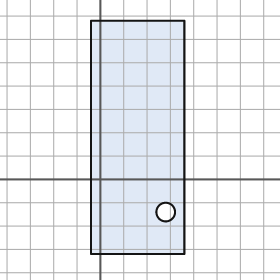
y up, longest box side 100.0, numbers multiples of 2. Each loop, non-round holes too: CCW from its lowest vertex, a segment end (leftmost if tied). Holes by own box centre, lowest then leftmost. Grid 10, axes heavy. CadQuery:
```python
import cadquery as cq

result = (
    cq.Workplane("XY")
    .moveTo(-4.0, -32.0)
    .lineTo(36.0, -32.0)
    .lineTo(36.0, 68.0)
    .lineTo(-4.0, 68.0)
    .close()
    .moveTo(28.0, -14.0)
    .circle(4.0)
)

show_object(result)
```